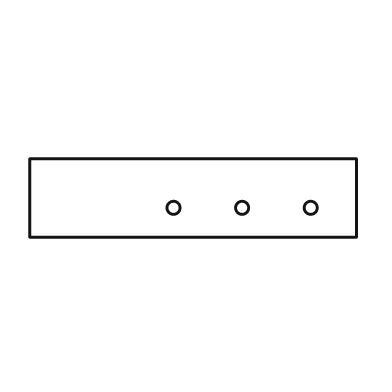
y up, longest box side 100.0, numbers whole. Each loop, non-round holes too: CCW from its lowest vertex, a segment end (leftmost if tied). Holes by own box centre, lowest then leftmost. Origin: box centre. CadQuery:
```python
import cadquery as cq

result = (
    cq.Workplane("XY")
    .moveTo(-50.0, -12.0)
    .lineTo(50.0, -12.0)
    .lineTo(50.0, 12.0)
    .lineTo(-50.0, 12.0)
    .close()
    .moveTo(-6.0, -3.0)
    .circle(2.0)
    .moveTo(15.0, -3.0)
    .circle(2.0)
    .moveTo(36.0, -3.0)
    .circle(2.0)
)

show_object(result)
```